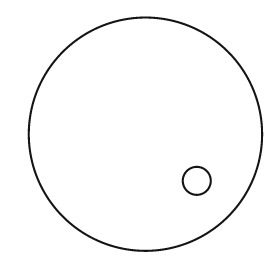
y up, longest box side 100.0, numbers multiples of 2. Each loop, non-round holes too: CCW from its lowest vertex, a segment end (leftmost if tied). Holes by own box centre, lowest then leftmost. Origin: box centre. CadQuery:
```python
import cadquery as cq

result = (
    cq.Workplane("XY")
    .moveTo(0.0, 0.0)
    .circle(50.0)
    .moveTo(22.0, -20.0)
    .circle(6.0)
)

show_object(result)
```